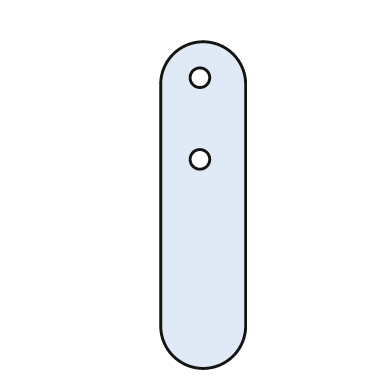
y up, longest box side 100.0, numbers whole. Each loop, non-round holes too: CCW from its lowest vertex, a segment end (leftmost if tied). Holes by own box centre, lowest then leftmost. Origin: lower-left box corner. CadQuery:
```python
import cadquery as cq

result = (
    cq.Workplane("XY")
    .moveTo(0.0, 13.0)
    .threePointArc((13.0, 0.0), (26.0, 13.0))
    .lineTo(26.0, 87.0)
    .threePointArc((13.0, 100.0), (0.0, 87.0))
    .close()
    .moveTo(12.0, 64.0)
    .circle(3.0)
    .moveTo(12.0, 89.0)
    .circle(3.0)
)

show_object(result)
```